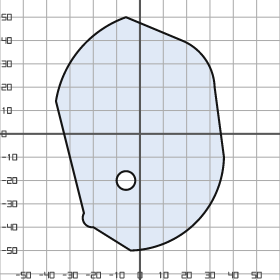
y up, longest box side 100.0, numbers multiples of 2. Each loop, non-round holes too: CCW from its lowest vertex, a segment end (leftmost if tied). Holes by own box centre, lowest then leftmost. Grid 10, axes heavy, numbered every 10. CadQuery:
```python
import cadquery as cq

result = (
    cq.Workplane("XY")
    .moveTo(-4.0, -50.0)
    .threePointArc((24.0, -38.0), (36.0, -10.0))
    .lineTo(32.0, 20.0)
    .threePointArc((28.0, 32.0), (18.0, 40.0))
    .lineTo(-6.0, 50.0)
    .threePointArc((-26.0, 36.0), (-36.0, 14.0))
    .lineTo(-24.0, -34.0)
    .threePointArc((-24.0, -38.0), (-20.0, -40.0))
    .close()
    .moveTo(-6.0, -20.0)
    .circle(4.0)
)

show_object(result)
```